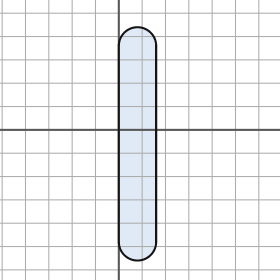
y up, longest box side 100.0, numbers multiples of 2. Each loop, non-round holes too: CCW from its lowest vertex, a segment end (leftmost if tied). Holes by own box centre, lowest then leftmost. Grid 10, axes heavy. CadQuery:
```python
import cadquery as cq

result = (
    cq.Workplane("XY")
    .moveTo(0.0, -48.0)
    .threePointArc((8.0, -56.0), (16.0, -48.0))
    .lineTo(16.0, 36.0)
    .threePointArc((8.0, 44.0), (0.0, 36.0))
    .close()
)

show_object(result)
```